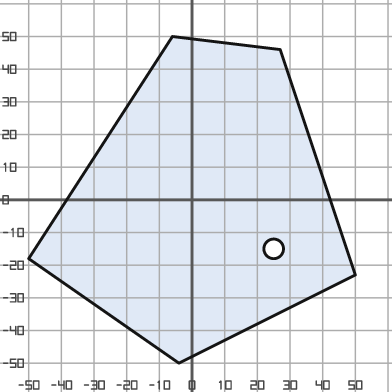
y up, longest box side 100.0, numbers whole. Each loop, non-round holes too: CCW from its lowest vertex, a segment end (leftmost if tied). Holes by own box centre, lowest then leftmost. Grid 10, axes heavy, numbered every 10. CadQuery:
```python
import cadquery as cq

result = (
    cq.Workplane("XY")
    .moveTo(-4.0, -50.0)
    .lineTo(50.0, -23.0)
    .lineTo(27.0, 46.0)
    .lineTo(-6.0, 50.0)
    .lineTo(-50.0, -18.0)
    .close()
    .moveTo(25.0, -15.0)
    .circle(3.0)
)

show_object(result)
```